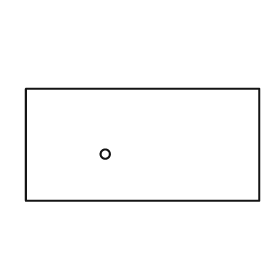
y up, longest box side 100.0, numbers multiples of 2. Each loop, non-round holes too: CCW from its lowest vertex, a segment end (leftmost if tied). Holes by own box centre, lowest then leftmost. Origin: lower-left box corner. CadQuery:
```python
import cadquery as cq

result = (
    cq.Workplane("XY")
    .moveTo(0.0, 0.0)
    .lineTo(100.0, 0.0)
    .lineTo(100.0, 48.0)
    .lineTo(0.0, 48.0)
    .close()
    .moveTo(34.0, 20.0)
    .circle(2.0)
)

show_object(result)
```